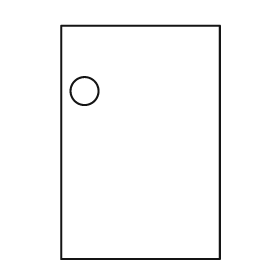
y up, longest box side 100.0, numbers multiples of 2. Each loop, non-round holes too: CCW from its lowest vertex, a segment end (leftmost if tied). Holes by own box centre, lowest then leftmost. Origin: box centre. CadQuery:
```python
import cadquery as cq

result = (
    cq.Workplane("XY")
    .moveTo(-34.0, -50.0)
    .lineTo(34.0, -50.0)
    .lineTo(34.0, 50.0)
    .lineTo(-34.0, 50.0)
    .close()
    .moveTo(-24.0, 22.0)
    .circle(6.0)
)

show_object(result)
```